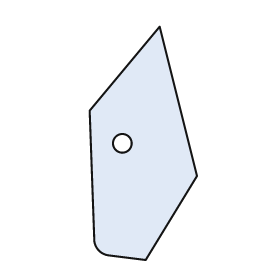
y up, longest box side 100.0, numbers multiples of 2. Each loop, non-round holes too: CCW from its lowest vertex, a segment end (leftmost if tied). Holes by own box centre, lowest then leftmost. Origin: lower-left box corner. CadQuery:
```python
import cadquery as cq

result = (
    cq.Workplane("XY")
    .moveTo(24.0, 0.0)
    .lineTo(46.0, 36.0)
    .lineTo(30.0, 100.0)
    .lineTo(0.0, 64.0)
    .lineTo(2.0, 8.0)
    .threePointArc((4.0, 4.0), (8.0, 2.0))
    .close()
    .moveTo(14.0, 50.0)
    .circle(4.0)
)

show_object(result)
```